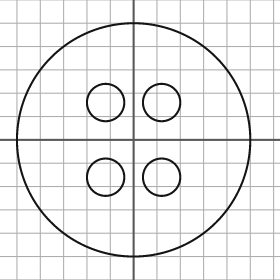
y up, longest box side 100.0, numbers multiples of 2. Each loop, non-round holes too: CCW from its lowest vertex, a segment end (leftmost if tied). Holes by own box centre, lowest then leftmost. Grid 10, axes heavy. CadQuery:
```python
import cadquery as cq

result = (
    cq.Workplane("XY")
    .moveTo(0.0, 0.0)
    .circle(50.0)
    .moveTo(-12.0, -16.0)
    .circle(8.0)
    .moveTo(12.0, -16.0)
    .circle(8.0)
    .moveTo(-12.0, 16.0)
    .circle(8.0)
    .moveTo(12.0, 16.0)
    .circle(8.0)
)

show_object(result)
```